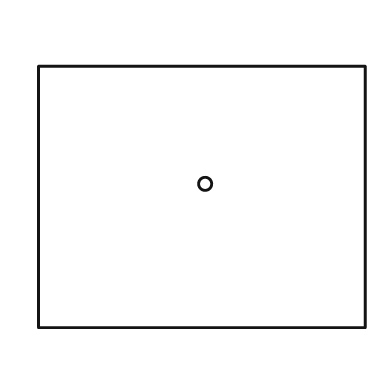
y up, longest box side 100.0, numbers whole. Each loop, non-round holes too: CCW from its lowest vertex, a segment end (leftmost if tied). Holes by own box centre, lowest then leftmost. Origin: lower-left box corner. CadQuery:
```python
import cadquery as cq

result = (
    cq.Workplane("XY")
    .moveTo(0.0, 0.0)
    .lineTo(100.0, 0.0)
    .lineTo(100.0, 80.0)
    .lineTo(0.0, 80.0)
    .close()
    .moveTo(51.0, 44.0)
    .circle(2.0)
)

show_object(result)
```